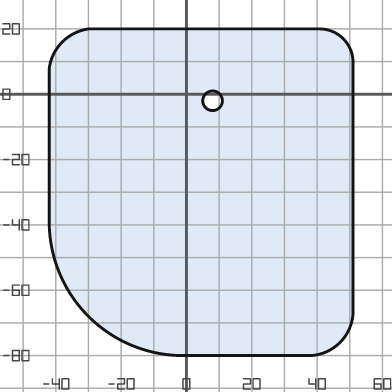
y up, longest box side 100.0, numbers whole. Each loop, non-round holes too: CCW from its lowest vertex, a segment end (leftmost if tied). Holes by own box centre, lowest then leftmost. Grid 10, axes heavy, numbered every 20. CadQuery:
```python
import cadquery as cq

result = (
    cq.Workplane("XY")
    .moveTo(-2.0, -80.0)
    .lineTo(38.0, -80.0)
    .threePointArc((47.0, -76.0), (51.0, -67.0))
    .lineTo(51.0, 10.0)
    .threePointArc((48.0, 17.0), (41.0, 20.0))
    .lineTo(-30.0, 20.0)
    .threePointArc((-38.0, 16.0), (-42.0, 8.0))
    .lineTo(-42.0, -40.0)
    .threePointArc((-30.0, -68.0), (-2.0, -80.0))
    .close()
    .moveTo(8.0, -2.0)
    .circle(3.0)
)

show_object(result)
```